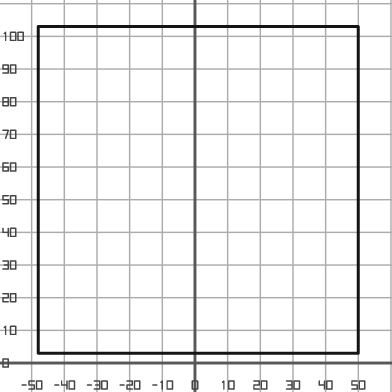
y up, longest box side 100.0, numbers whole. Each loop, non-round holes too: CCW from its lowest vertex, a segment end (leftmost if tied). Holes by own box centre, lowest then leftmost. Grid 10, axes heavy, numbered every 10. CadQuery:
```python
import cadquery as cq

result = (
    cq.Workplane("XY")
    .moveTo(-48.0, 3.0)
    .lineTo(50.0, 3.0)
    .lineTo(50.0, 103.0)
    .lineTo(-48.0, 103.0)
    .close()
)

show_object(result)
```